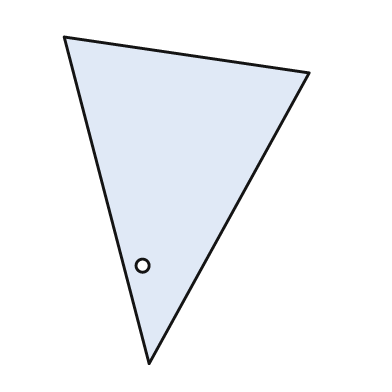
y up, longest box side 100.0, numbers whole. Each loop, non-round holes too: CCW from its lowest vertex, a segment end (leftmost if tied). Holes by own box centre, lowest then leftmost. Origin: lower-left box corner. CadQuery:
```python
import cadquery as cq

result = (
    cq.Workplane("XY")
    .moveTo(26.0, 0.0)
    .lineTo(75.0, 89.0)
    .lineTo(0.0, 100.0)
    .close()
    .moveTo(24.0, 30.0)
    .circle(2.0)
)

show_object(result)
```